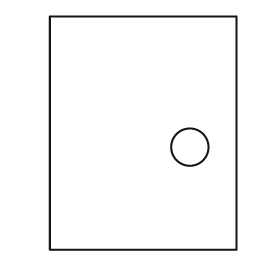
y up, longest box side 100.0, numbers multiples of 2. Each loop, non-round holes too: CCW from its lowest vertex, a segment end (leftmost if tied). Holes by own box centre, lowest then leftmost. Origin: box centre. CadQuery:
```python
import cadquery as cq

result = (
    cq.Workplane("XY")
    .moveTo(-40.0, -50.0)
    .lineTo(40.0, -50.0)
    .lineTo(40.0, 50.0)
    .lineTo(-40.0, 50.0)
    .close()
    .moveTo(20.0, -6.0)
    .circle(8.0)
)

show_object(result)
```